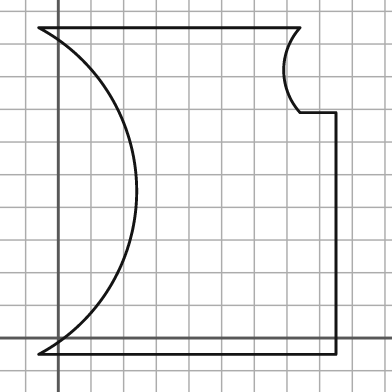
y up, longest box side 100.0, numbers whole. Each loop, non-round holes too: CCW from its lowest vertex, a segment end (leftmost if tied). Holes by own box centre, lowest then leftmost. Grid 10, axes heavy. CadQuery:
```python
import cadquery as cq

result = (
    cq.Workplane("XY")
    .moveTo(-6.0, -5.0)
    .lineTo(85.0, -5.0)
    .lineTo(85.0, 69.0)
    .lineTo(74.0, 69.0)
    .threePointArc((69.0, 82.0), (74.0, 95.0))
    .lineTo(-6.0, 95.0)
    .threePointArc((24.0, 45.0), (-6.0, -5.0))
    .close()
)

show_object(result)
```